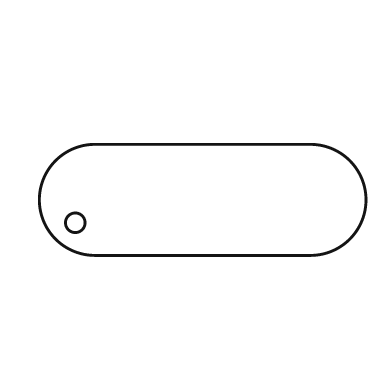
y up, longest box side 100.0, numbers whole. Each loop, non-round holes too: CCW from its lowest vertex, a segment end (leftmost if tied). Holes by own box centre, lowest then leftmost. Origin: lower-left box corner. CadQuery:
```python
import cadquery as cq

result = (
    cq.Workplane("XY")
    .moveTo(17.0, 0.0)
    .lineTo(83.0, 0.0)
    .threePointArc((100.0, 17.0), (83.0, 34.0))
    .lineTo(17.0, 34.0)
    .threePointArc((0.0, 17.0), (17.0, 0.0))
    .close()
    .moveTo(11.0, 10.0)
    .circle(3.0)
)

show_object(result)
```